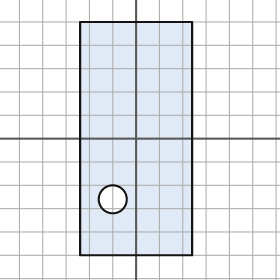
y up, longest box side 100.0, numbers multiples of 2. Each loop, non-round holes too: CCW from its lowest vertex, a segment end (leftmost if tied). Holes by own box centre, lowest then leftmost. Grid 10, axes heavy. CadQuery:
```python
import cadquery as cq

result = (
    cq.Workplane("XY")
    .moveTo(-24.0, -50.0)
    .lineTo(24.0, -50.0)
    .lineTo(24.0, 50.0)
    .lineTo(-24.0, 50.0)
    .close()
    .moveTo(-10.0, -26.0)
    .circle(6.0)
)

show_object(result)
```